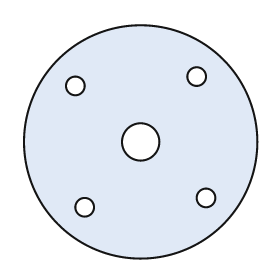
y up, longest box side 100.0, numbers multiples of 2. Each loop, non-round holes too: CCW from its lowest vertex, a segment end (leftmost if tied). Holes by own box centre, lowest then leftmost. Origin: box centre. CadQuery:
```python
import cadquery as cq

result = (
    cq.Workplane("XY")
    .moveTo(0.0, 0.0)
    .circle(50.0)
    .moveTo(-24.0, -28.0)
    .circle(4.0)
    .moveTo(28.0, -24.0)
    .circle(4.0)
    .moveTo(0.0, 0.0)
    .circle(8.0)
    .moveTo(-28.0, 24.0)
    .circle(4.0)
    .moveTo(24.0, 28.0)
    .circle(4.0)
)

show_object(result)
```